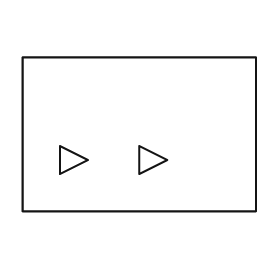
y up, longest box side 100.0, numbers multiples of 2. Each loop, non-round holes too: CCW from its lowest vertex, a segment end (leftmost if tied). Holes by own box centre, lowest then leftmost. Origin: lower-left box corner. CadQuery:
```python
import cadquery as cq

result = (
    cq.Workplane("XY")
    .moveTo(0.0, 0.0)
    .lineTo(100.0, 0.0)
    .lineTo(100.0, 66.0)
    .lineTo(0.0, 66.0)
    .close()
    .moveTo(16.0, 16.0)
    .lineTo(28.0, 22.0)
    .lineTo(16.0, 28.0)
    .close()
    .moveTo(50.0, 16.0)
    .lineTo(62.0, 22.0)
    .lineTo(50.0, 28.0)
    .close()
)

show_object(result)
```